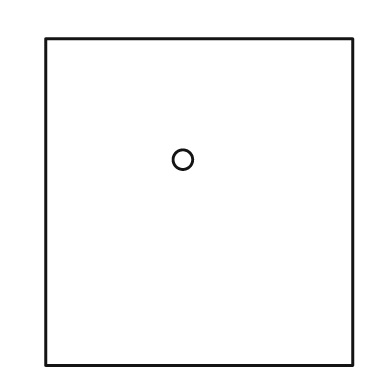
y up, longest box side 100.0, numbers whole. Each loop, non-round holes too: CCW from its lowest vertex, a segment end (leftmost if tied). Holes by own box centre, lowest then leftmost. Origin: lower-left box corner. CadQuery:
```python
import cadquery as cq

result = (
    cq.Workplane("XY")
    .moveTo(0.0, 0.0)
    .lineTo(94.0, 0.0)
    .lineTo(94.0, 100.0)
    .lineTo(0.0, 100.0)
    .close()
    .moveTo(42.0, 63.0)
    .circle(3.0)
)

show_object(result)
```